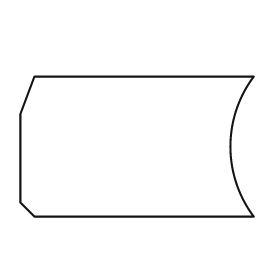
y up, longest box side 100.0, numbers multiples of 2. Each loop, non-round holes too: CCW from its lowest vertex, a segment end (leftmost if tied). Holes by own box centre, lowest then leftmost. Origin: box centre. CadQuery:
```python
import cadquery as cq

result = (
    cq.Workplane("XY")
    .moveTo(-44.0, -30.0)
    .lineTo(50.0, -30.0)
    .threePointArc((40.0, 0.0), (50.0, 30.0))
    .lineTo(-44.0, 30.0)
    .lineTo(-50.0, 14.0)
    .lineTo(-50.0, -24.0)
    .close()
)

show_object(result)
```